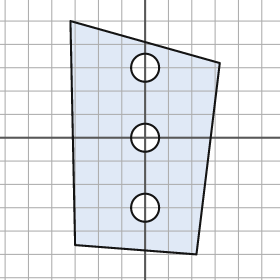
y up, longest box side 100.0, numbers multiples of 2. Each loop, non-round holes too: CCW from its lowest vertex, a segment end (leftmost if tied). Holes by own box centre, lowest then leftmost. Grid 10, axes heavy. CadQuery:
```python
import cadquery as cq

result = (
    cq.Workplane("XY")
    .moveTo(22.0, -50.0)
    .lineTo(32.0, 32.0)
    .lineTo(-32.0, 50.0)
    .lineTo(-30.0, -46.0)
    .close()
    .moveTo(0.0, -30.0)
    .circle(6.0)
    .moveTo(0.0, 0.0)
    .circle(6.0)
    .moveTo(0.0, 30.0)
    .circle(6.0)
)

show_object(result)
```